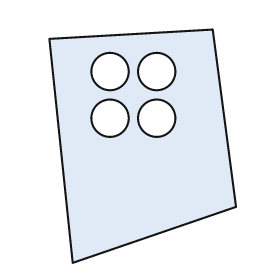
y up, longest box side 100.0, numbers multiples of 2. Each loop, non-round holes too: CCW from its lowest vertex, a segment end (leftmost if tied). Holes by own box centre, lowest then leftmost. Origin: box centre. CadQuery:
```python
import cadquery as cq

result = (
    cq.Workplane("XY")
    .moveTo(-30.0, -50.0)
    .lineTo(40.0, -26.0)
    .lineTo(30.0, 50.0)
    .lineTo(-40.0, 46.0)
    .close()
    .moveTo(-14.0, 12.0)
    .circle(8.0)
    .moveTo(6.0, 12.0)
    .circle(8.0)
    .moveTo(-14.0, 32.0)
    .circle(8.0)
    .moveTo(6.0, 32.0)
    .circle(8.0)
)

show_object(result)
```